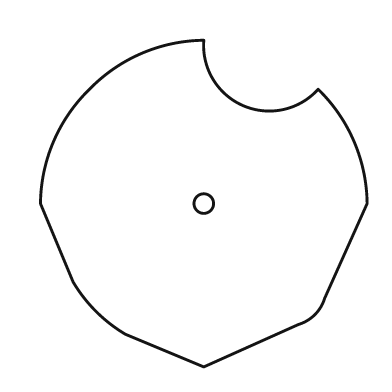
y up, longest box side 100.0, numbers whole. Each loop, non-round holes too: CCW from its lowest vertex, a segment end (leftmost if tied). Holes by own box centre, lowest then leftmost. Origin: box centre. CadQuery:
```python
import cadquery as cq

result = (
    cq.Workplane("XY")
    .moveTo(0.0, -50.0)
    .lineTo(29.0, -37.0)
    .threePointArc((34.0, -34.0), (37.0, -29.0))
    .lineTo(50.0, 0.0)
    .threePointArc((46.0, 19.0), (35.0, 35.0))
    .threePointArc((12.0, 30.0), (0.0, 50.0))
    .threePointArc((-19.0, 46.0), (-35.0, 35.0))
    .threePointArc((-46.0, 19.0), (-50.0, 0.0))
    .lineTo(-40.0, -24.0)
    .threePointArc((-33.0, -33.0), (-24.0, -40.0))
    .close()
    .moveTo(0.0, 0.0)
    .circle(3.0)
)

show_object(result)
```